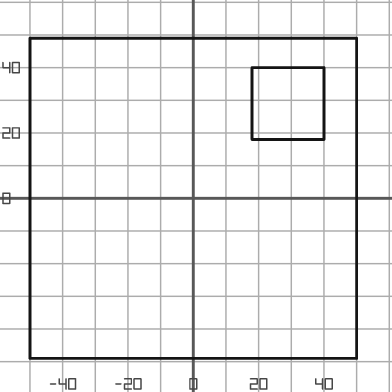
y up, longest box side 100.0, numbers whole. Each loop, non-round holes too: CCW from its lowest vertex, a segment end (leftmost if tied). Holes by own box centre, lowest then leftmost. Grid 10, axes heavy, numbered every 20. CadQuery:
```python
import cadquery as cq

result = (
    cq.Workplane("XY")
    .moveTo(-50.0, -49.0)
    .lineTo(50.0, -49.0)
    .lineTo(50.0, 49.0)
    .lineTo(-50.0, 49.0)
    .close()
    .moveTo(18.0, 18.0)
    .lineTo(40.0, 18.0)
    .lineTo(40.0, 40.0)
    .lineTo(18.0, 40.0)
    .close()
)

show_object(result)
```